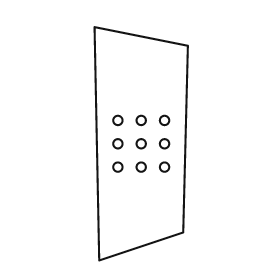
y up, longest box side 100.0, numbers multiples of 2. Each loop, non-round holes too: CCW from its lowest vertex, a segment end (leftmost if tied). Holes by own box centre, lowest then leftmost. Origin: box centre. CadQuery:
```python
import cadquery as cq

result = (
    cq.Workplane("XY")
    .moveTo(-18.0, -50.0)
    .lineTo(18.0, -38.0)
    .lineTo(20.0, 42.0)
    .lineTo(-20.0, 50.0)
    .close()
    .moveTo(-10.0, -10.0)
    .circle(2.0)
    .moveTo(0.0, -10.0)
    .circle(2.0)
    .moveTo(10.0, -10.0)
    .circle(2.0)
    .moveTo(-10.0, 0.0)
    .circle(2.0)
    .moveTo(0.0, 0.0)
    .circle(2.0)
    .moveTo(10.0, 0.0)
    .circle(2.0)
    .moveTo(-10.0, 10.0)
    .circle(2.0)
    .moveTo(0.0, 10.0)
    .circle(2.0)
    .moveTo(10.0, 10.0)
    .circle(2.0)
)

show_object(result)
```